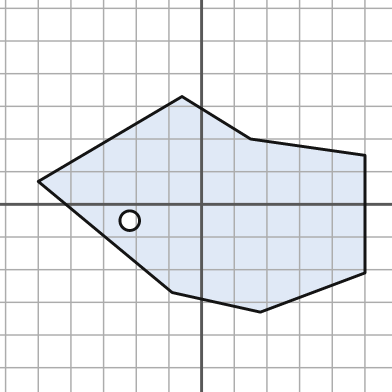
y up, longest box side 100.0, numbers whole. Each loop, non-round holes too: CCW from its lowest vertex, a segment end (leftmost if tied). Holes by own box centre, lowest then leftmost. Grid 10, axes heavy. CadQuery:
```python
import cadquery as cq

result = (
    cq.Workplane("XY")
    .moveTo(18.0, -33.0)
    .lineTo(50.0, -21.0)
    .lineTo(50.0, 15.0)
    .lineTo(15.0, 20.0)
    .lineTo(-6.0, 33.0)
    .lineTo(-50.0, 7.0)
    .lineTo(-9.0, -27.0)
    .close()
    .moveTo(-22.0, -5.0)
    .circle(3.0)
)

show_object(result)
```